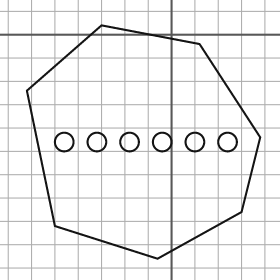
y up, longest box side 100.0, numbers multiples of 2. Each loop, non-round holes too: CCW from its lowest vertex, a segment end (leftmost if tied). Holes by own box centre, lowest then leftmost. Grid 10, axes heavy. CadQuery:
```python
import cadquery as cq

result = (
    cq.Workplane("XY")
    .moveTo(-6.0, -96.0)
    .lineTo(30.0, -76.0)
    .lineTo(38.0, -44.0)
    .lineTo(12.0, -4.0)
    .lineTo(-30.0, 4.0)
    .lineTo(-62.0, -24.0)
    .lineTo(-50.0, -82.0)
    .close()
    .moveTo(-46.0, -46.0)
    .circle(4.0)
    .moveTo(-32.0, -46.0)
    .circle(4.0)
    .moveTo(-18.0, -46.0)
    .circle(4.0)
    .moveTo(-4.0, -46.0)
    .circle(4.0)
    .moveTo(10.0, -46.0)
    .circle(4.0)
    .moveTo(24.0, -46.0)
    .circle(4.0)
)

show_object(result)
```